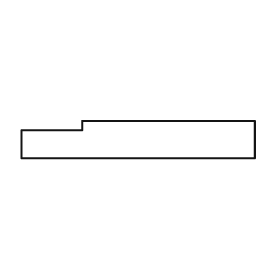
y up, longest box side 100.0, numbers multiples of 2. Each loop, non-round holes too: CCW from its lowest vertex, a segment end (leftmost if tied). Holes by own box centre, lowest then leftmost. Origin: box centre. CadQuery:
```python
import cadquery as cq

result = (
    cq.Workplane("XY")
    .moveTo(-50.0, -8.0)
    .lineTo(50.0, -8.0)
    .lineTo(50.0, 8.0)
    .lineTo(-24.0, 8.0)
    .lineTo(-24.0, 4.0)
    .lineTo(-50.0, 4.0)
    .close()
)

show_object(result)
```